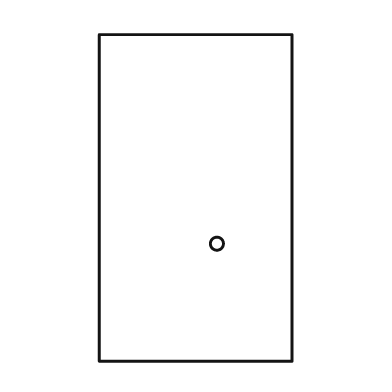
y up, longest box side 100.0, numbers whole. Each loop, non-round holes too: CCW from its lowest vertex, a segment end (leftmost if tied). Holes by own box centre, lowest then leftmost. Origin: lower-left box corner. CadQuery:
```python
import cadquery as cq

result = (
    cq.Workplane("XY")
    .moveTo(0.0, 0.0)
    .lineTo(59.0, 0.0)
    .lineTo(59.0, 100.0)
    .lineTo(0.0, 100.0)
    .close()
    .moveTo(36.0, 36.0)
    .circle(2.0)
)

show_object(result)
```